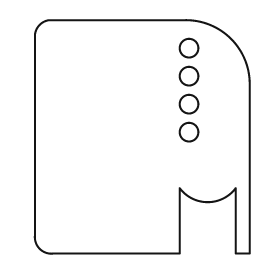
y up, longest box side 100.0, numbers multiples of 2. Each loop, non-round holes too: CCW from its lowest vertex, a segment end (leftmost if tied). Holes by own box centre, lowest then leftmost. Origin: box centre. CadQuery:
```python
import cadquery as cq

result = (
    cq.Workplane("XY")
    .moveTo(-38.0, -50.0)
    .lineTo(16.0, -50.0)
    .lineTo(16.0, -22.0)
    .threePointArc((28.0, -28.0), (40.0, -22.0))
    .lineTo(40.0, -50.0)
    .lineTo(46.0, -50.0)
    .lineTo(46.0, 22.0)
    .threePointArc((38.0, 42.0), (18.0, 50.0))
    .lineTo(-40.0, 50.0)
    .threePointArc((-44.0, 48.0), (-46.0, 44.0))
    .lineTo(-46.0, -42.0)
    .threePointArc((-44.0, -48.0), (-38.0, -50.0))
    .close()
    .moveTo(20.0, 2.0)
    .circle(4.0)
    .moveTo(20.0, 14.0)
    .circle(4.0)
    .moveTo(20.0, 26.0)
    .circle(4.0)
    .moveTo(20.0, 38.0)
    .circle(4.0)
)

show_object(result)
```